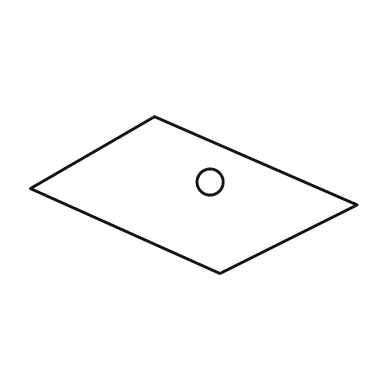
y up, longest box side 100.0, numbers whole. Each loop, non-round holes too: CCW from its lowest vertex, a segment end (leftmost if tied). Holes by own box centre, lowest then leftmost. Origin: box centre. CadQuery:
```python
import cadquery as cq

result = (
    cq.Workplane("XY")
    .moveTo(8.0, -24.0)
    .lineTo(50.0, -3.0)
    .lineTo(-12.0, 24.0)
    .lineTo(-50.0, 2.0)
    .close()
    .moveTo(5.0, 4.0)
    .circle(4.0)
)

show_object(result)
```